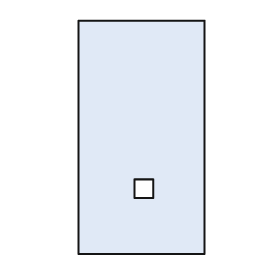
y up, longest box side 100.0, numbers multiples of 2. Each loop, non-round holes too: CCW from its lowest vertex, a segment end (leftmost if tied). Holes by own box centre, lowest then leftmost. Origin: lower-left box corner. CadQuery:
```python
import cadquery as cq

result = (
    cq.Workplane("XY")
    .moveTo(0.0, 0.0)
    .lineTo(54.0, 0.0)
    .lineTo(54.0, 100.0)
    .lineTo(0.0, 100.0)
    .close()
    .moveTo(24.0, 24.0)
    .lineTo(32.0, 24.0)
    .lineTo(32.0, 32.0)
    .lineTo(24.0, 32.0)
    .close()
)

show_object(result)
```